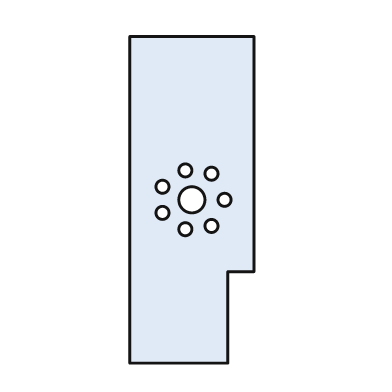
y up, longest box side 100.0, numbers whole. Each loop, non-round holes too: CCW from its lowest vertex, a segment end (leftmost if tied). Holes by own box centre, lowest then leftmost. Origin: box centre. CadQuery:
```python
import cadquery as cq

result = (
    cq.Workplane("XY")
    .moveTo(-19.0, -50.0)
    .lineTo(11.0, -50.0)
    .lineTo(11.0, -22.0)
    .lineTo(19.0, -22.0)
    .lineTo(19.0, 50.0)
    .lineTo(-19.0, 50.0)
    .close()
    .moveTo(-2.0, -9.0)
    .circle(2.0)
    .moveTo(6.0, -8.0)
    .circle(2.0)
    .moveTo(-9.0, -4.0)
    .circle(2.0)
    .moveTo(0.0, 0.0)
    .circle(4.0)
    .moveTo(10.0, 0.0)
    .circle(2.0)
    .moveTo(-9.0, 4.0)
    .circle(2.0)
    .moveTo(6.0, 8.0)
    .circle(2.0)
    .moveTo(-2.0, 9.0)
    .circle(2.0)
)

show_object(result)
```